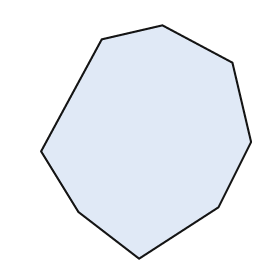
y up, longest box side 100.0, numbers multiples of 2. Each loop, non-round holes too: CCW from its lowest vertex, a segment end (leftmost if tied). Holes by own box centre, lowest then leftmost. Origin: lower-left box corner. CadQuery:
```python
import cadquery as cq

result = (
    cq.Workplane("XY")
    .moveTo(42.0, 0.0)
    .lineTo(76.0, 22.0)
    .lineTo(90.0, 50.0)
    .lineTo(82.0, 84.0)
    .lineTo(52.0, 100.0)
    .lineTo(26.0, 94.0)
    .lineTo(0.0, 46.0)
    .lineTo(16.0, 20.0)
    .close()
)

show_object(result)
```